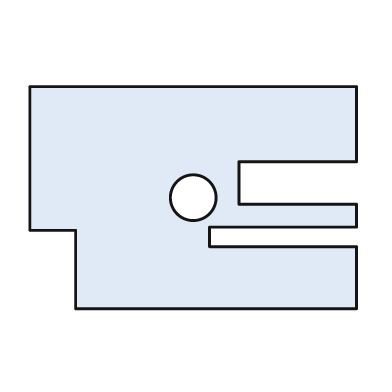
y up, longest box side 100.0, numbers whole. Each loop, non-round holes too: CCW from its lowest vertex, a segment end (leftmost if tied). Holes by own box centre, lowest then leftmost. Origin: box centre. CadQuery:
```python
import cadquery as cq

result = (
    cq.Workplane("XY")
    .moveTo(-36.0, -34.0)
    .lineTo(50.0, -34.0)
    .lineTo(50.0, -15.0)
    .lineTo(5.0, -15.0)
    .lineTo(5.0, -9.0)
    .lineTo(50.0, -9.0)
    .lineTo(50.0, -2.0)
    .lineTo(14.0, -2.0)
    .lineTo(14.0, 11.0)
    .lineTo(50.0, 11.0)
    .lineTo(50.0, 34.0)
    .lineTo(-50.0, 34.0)
    .lineTo(-50.0, -10.0)
    .lineTo(-36.0, -10.0)
    .close()
    .moveTo(0.0, 0.0)
    .circle(7.0)
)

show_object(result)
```